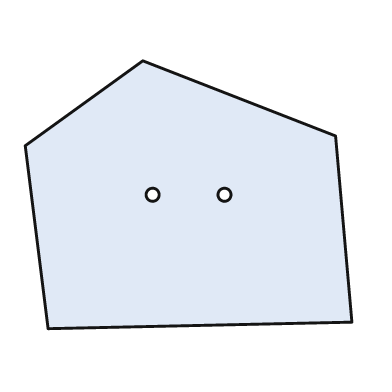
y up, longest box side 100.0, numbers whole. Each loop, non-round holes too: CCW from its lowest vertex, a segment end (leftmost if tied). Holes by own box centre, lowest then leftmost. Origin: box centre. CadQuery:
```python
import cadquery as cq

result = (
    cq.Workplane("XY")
    .moveTo(-43.0, -41.0)
    .lineTo(50.0, -39.0)
    .lineTo(45.0, 18.0)
    .lineTo(-14.0, 41.0)
    .lineTo(-50.0, 15.0)
    .close()
    .moveTo(-11.0, 0.0)
    .circle(2.0)
    .moveTo(11.0, 0.0)
    .circle(2.0)
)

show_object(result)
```